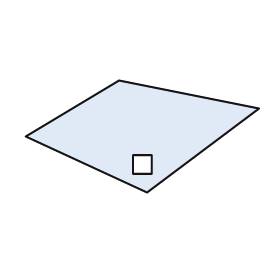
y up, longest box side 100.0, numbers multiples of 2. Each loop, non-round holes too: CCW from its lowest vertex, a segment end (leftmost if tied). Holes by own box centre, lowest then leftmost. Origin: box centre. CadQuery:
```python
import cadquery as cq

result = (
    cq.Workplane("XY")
    .moveTo(2.0, -24.0)
    .lineTo(50.0, 12.0)
    .lineTo(-10.0, 24.0)
    .lineTo(-50.0, 0.0)
    .close()
    .moveTo(-4.0, -16.0)
    .lineTo(4.0, -16.0)
    .lineTo(4.0, -8.0)
    .lineTo(-4.0, -8.0)
    .close()
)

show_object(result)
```